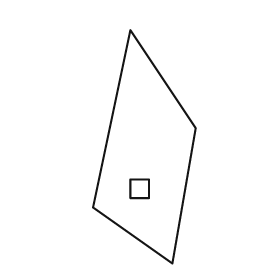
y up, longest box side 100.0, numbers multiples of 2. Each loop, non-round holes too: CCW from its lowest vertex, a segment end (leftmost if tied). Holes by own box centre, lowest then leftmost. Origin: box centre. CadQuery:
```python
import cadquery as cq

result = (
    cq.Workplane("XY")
    .moveTo(12.0, -50.0)
    .lineTo(22.0, 8.0)
    .lineTo(-6.0, 50.0)
    .lineTo(-22.0, -26.0)
    .close()
    .moveTo(-6.0, -22.0)
    .lineTo(2.0, -22.0)
    .lineTo(2.0, -14.0)
    .lineTo(-6.0, -14.0)
    .close()
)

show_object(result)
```